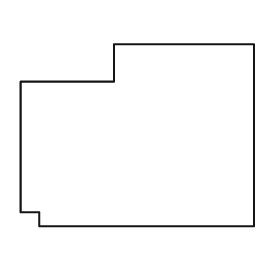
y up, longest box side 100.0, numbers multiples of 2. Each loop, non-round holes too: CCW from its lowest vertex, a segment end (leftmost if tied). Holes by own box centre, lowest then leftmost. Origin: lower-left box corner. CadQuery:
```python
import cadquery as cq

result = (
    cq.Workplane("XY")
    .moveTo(8.0, 0.0)
    .lineTo(100.0, 0.0)
    .lineTo(100.0, 78.0)
    .lineTo(40.0, 78.0)
    .lineTo(40.0, 62.0)
    .lineTo(0.0, 62.0)
    .lineTo(0.0, 6.0)
    .lineTo(8.0, 6.0)
    .close()
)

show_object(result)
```